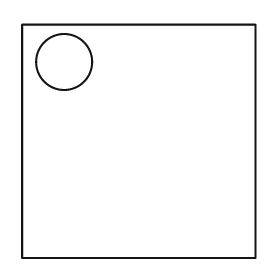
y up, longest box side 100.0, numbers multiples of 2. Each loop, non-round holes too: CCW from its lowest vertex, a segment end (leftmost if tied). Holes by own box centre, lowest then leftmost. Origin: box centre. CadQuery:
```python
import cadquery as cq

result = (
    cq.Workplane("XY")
    .moveTo(-50.0, -50.0)
    .lineTo(50.0, -50.0)
    .lineTo(50.0, 50.0)
    .lineTo(-50.0, 50.0)
    .close()
    .moveTo(-32.0, 34.0)
    .circle(12.0)
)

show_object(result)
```